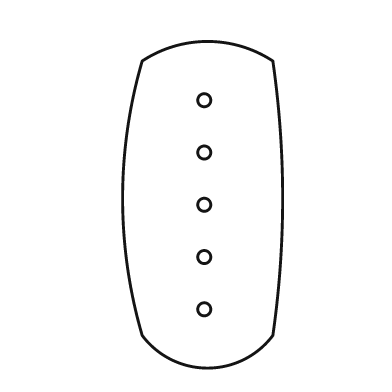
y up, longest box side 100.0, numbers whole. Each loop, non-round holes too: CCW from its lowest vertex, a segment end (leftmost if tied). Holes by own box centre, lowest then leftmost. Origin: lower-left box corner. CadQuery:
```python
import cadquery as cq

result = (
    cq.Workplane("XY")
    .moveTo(6.0, 10.0)
    .threePointArc((26.0, 0.0), (46.0, 10.0))
    .threePointArc((49.0, 52.0), (46.0, 94.0))
    .threePointArc((26.0, 100.0), (6.0, 94.0))
    .threePointArc((0.0, 52.0), (6.0, 10.0))
    .close()
    .moveTo(25.0, 18.0)
    .circle(2.0)
    .moveTo(25.0, 34.0)
    .circle(2.0)
    .moveTo(25.0, 50.0)
    .circle(2.0)
    .moveTo(25.0, 66.0)
    .circle(2.0)
    .moveTo(25.0, 82.0)
    .circle(2.0)
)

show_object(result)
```